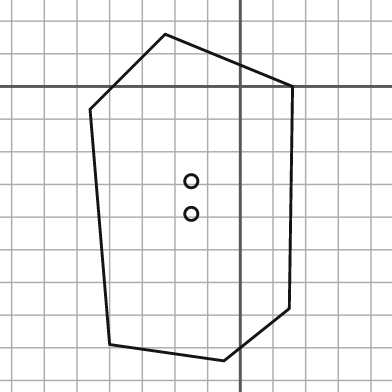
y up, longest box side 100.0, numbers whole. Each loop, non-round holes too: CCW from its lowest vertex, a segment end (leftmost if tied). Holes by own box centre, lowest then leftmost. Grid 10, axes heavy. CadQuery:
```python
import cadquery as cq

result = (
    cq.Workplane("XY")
    .moveTo(-5.0, -84.0)
    .lineTo(15.0, -68.0)
    .lineTo(16.0, 0.0)
    .lineTo(-23.0, 16.0)
    .lineTo(-46.0, -7.0)
    .lineTo(-40.0, -79.0)
    .close()
    .moveTo(-15.0, -39.0)
    .circle(2.0)
    .moveTo(-15.0, -29.0)
    .circle(2.0)
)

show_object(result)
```